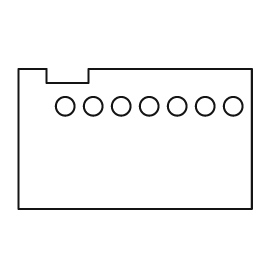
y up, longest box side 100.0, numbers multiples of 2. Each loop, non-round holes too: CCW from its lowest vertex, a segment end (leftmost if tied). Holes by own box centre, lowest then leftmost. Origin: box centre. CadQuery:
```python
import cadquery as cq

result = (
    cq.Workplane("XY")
    .moveTo(-50.0, -30.0)
    .lineTo(50.0, -30.0)
    .lineTo(50.0, 30.0)
    .lineTo(-20.0, 30.0)
    .lineTo(-20.0, 24.0)
    .lineTo(-38.0, 24.0)
    .lineTo(-38.0, 30.0)
    .lineTo(-50.0, 30.0)
    .close()
    .moveTo(-30.0, 14.0)
    .circle(4.0)
    .moveTo(-18.0, 14.0)
    .circle(4.0)
    .moveTo(-6.0, 14.0)
    .circle(4.0)
    .moveTo(6.0, 14.0)
    .circle(4.0)
    .moveTo(18.0, 14.0)
    .circle(4.0)
    .moveTo(30.0, 14.0)
    .circle(4.0)
    .moveTo(42.0, 14.0)
    .circle(4.0)
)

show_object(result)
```